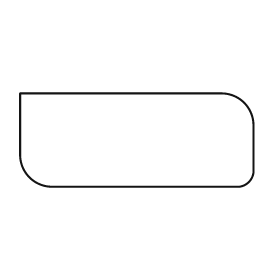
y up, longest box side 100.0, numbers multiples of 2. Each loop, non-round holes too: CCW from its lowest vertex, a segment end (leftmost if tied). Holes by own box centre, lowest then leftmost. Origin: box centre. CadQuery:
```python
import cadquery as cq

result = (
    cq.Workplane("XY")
    .moveTo(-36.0, -20.0)
    .lineTo(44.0, -20.0)
    .threePointArc((48.0, -18.0), (50.0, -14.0))
    .lineTo(50.0, 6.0)
    .threePointArc((46.0, 16.0), (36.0, 20.0))
    .lineTo(-50.0, 20.0)
    .lineTo(-50.0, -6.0)
    .threePointArc((-46.0, -16.0), (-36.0, -20.0))
    .close()
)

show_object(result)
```